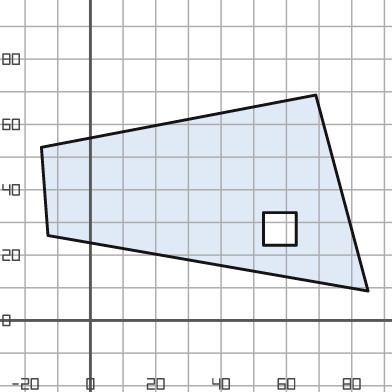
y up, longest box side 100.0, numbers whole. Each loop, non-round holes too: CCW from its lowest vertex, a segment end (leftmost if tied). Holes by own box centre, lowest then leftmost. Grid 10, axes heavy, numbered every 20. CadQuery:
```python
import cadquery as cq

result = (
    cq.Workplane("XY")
    .moveTo(85.0, 9.0)
    .lineTo(69.0, 69.0)
    .lineTo(-15.0, 53.0)
    .lineTo(-13.0, 26.0)
    .close()
    .moveTo(53.0, 23.0)
    .lineTo(63.0, 23.0)
    .lineTo(63.0, 33.0)
    .lineTo(53.0, 33.0)
    .close()
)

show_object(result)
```